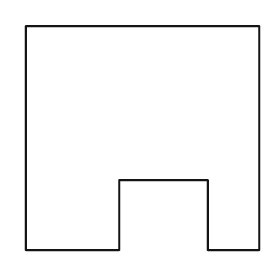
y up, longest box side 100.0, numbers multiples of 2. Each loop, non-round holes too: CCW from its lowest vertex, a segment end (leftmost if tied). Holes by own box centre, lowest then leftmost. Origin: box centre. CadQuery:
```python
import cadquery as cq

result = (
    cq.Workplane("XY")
    .moveTo(-50.0, -48.0)
    .lineTo(-10.0, -48.0)
    .lineTo(-10.0, -18.0)
    .lineTo(28.0, -18.0)
    .lineTo(28.0, -48.0)
    .lineTo(50.0, -48.0)
    .lineTo(50.0, 48.0)
    .lineTo(-50.0, 48.0)
    .close()
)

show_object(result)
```